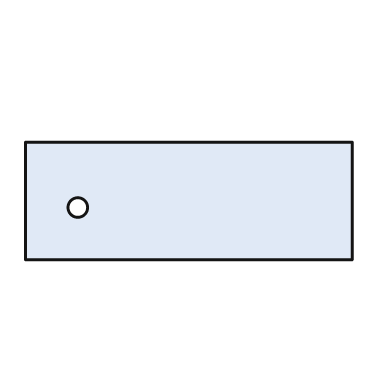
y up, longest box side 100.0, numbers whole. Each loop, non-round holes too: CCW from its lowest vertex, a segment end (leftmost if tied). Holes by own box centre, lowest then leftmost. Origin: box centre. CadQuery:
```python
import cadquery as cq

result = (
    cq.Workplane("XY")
    .moveTo(-50.0, -18.0)
    .lineTo(50.0, -18.0)
    .lineTo(50.0, 18.0)
    .lineTo(-50.0, 18.0)
    .close()
    .moveTo(-34.0, -2.0)
    .circle(3.0)
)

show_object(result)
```